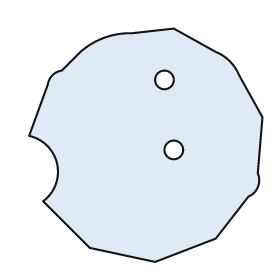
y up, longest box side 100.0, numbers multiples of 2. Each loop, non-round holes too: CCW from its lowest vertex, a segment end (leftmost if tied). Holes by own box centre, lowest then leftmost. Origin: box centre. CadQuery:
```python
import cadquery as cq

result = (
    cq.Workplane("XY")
    .moveTo(4.0, -50.0)
    .lineTo(30.0, -40.0)
    .lineTo(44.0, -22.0)
    .threePointArc((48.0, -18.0), (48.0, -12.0))
    .lineTo(50.0, 12.0)
    .lineTo(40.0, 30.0)
    .threePointArc((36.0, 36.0), (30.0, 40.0))
    .lineTo(12.0, 50.0)
    .lineTo(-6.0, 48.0)
    .threePointArc((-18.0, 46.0), (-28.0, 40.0))
    .lineTo(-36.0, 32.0)
    .threePointArc((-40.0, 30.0), (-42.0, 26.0))
    .lineTo(-50.0, 4.0)
    .threePointArc((-38.0, -8.0), (-44.0, -24.0))
    .lineTo(-24.0, -44.0)
    .close()
    .moveTo(12.0, -2.0)
    .circle(4.0)
    .moveTo(8.0, 28.0)
    .circle(4.0)
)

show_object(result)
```